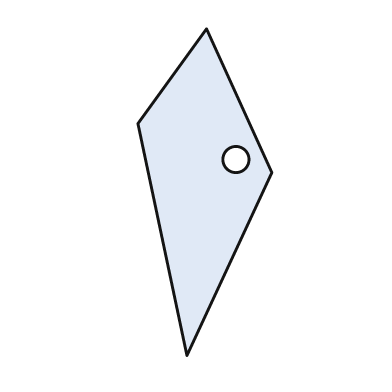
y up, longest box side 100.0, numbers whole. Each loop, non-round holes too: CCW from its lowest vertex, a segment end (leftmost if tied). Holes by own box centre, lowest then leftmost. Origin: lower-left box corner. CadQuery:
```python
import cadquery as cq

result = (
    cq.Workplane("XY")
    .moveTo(15.0, 0.0)
    .lineTo(41.0, 56.0)
    .lineTo(21.0, 100.0)
    .lineTo(0.0, 71.0)
    .close()
    .moveTo(30.0, 60.0)
    .circle(4.0)
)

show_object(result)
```